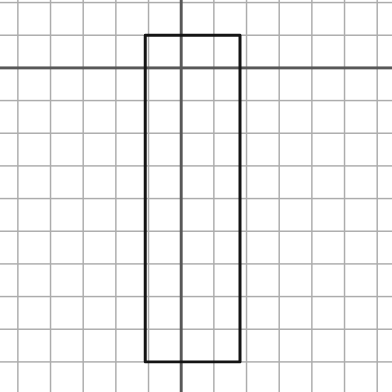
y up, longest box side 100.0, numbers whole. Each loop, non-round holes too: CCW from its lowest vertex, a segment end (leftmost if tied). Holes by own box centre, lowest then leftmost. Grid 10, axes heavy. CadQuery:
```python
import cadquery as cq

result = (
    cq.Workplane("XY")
    .moveTo(-11.0, -90.0)
    .lineTo(18.0, -90.0)
    .lineTo(18.0, 10.0)
    .lineTo(-11.0, 10.0)
    .close()
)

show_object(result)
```